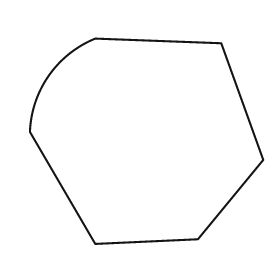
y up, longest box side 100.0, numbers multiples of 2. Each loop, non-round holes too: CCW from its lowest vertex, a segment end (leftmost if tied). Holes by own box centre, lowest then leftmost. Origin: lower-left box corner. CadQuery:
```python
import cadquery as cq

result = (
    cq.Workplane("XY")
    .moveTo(28.0, 0.0)
    .lineTo(72.0, 2.0)
    .lineTo(100.0, 36.0)
    .lineTo(82.0, 86.0)
    .lineTo(28.0, 88.0)
    .threePointArc((8.0, 72.0), (0.0, 48.0))
    .close()
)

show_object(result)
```